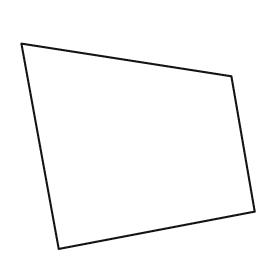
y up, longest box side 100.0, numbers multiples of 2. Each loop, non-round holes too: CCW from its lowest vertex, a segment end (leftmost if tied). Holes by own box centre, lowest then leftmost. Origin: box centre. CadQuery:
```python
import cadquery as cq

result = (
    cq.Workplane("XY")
    .moveTo(-34.0, -44.0)
    .lineTo(50.0, -28.0)
    .lineTo(40.0, 30.0)
    .lineTo(-50.0, 44.0)
    .close()
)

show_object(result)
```